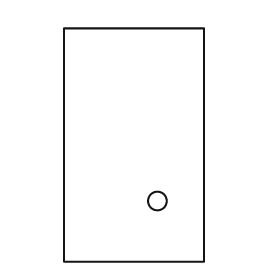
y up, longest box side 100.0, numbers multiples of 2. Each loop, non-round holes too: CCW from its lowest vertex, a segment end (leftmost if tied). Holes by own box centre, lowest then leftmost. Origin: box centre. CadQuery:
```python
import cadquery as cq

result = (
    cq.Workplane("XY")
    .moveTo(-30.0, -50.0)
    .lineTo(30.0, -50.0)
    .lineTo(30.0, 50.0)
    .lineTo(-30.0, 50.0)
    .close()
    .moveTo(10.0, -24.0)
    .circle(4.0)
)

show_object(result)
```